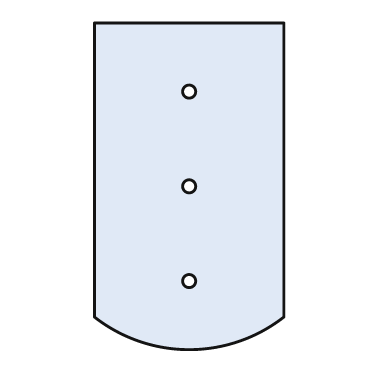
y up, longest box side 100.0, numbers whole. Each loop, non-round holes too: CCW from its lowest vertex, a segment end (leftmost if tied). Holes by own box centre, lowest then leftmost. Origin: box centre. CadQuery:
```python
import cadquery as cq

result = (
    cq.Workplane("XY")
    .moveTo(-29.0, -40.0)
    .threePointArc((0.0, -50.0), (29.0, -40.0))
    .lineTo(29.0, 50.0)
    .lineTo(-29.0, 50.0)
    .close()
    .moveTo(0.0, -29.0)
    .circle(2.0)
    .moveTo(0.0, 0.0)
    .circle(2.0)
    .moveTo(0.0, 29.0)
    .circle(2.0)
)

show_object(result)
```